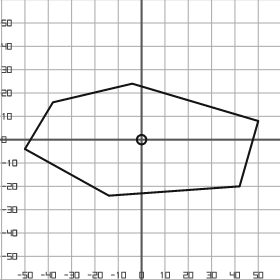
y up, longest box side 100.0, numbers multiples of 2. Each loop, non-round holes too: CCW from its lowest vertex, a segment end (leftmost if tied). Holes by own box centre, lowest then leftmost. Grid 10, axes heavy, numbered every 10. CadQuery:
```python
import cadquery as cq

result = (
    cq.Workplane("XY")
    .moveTo(-14.0, -24.0)
    .lineTo(42.0, -20.0)
    .lineTo(50.0, 8.0)
    .lineTo(-4.0, 24.0)
    .lineTo(-38.0, 16.0)
    .lineTo(-50.0, -4.0)
    .close()
    .moveTo(0.0, 0.0)
    .circle(2.0)
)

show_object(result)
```